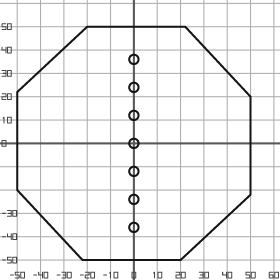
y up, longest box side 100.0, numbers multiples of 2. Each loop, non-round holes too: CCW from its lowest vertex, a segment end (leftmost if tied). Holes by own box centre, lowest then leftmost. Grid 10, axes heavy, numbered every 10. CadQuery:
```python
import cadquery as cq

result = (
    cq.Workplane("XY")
    .moveTo(-22.0, -50.0)
    .lineTo(20.0, -50.0)
    .lineTo(50.0, -22.0)
    .lineTo(50.0, 20.0)
    .lineTo(22.0, 50.0)
    .lineTo(-20.0, 50.0)
    .lineTo(-50.0, 22.0)
    .lineTo(-50.0, -20.0)
    .close()
    .moveTo(0.0, -36.0)
    .circle(2.0)
    .moveTo(0.0, -24.0)
    .circle(2.0)
    .moveTo(0.0, -12.0)
    .circle(2.0)
    .moveTo(0.0, 0.0)
    .circle(2.0)
    .moveTo(0.0, 12.0)
    .circle(2.0)
    .moveTo(0.0, 24.0)
    .circle(2.0)
    .moveTo(0.0, 36.0)
    .circle(2.0)
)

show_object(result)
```